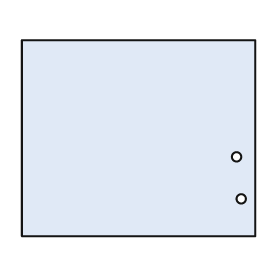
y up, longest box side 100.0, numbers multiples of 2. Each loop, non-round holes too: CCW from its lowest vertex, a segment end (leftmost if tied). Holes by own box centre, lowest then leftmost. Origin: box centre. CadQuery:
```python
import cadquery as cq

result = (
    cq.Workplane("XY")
    .moveTo(-50.0, -42.0)
    .lineTo(50.0, -42.0)
    .lineTo(50.0, 42.0)
    .lineTo(-50.0, 42.0)
    .close()
    .moveTo(44.0, -26.0)
    .circle(2.0)
    .moveTo(42.0, -8.0)
    .circle(2.0)
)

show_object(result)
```